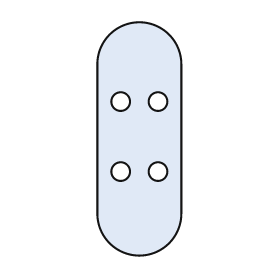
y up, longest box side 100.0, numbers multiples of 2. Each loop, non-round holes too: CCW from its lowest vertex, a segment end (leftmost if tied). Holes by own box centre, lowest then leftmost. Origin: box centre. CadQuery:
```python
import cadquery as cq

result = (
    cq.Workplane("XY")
    .moveTo(-18.0, -32.0)
    .threePointArc((0.0, -50.0), (18.0, -32.0))
    .lineTo(18.0, 32.0)
    .threePointArc((0.0, 50.0), (-18.0, 32.0))
    .close()
    .moveTo(-8.0, -14.0)
    .circle(4.0)
    .moveTo(8.0, -14.0)
    .circle(4.0)
    .moveTo(-8.0, 16.0)
    .circle(4.0)
    .moveTo(8.0, 16.0)
    .circle(4.0)
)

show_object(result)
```